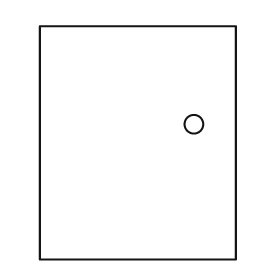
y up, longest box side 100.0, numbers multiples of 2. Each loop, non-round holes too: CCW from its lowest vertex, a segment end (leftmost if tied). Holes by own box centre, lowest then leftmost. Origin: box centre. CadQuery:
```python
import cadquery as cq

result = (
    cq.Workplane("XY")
    .moveTo(-42.0, -50.0)
    .lineTo(42.0, -50.0)
    .lineTo(42.0, 50.0)
    .lineTo(-42.0, 50.0)
    .close()
    .moveTo(24.0, 8.0)
    .circle(4.0)
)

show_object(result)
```